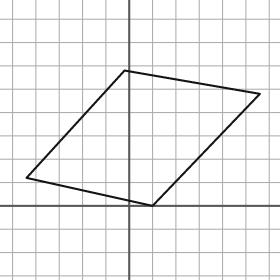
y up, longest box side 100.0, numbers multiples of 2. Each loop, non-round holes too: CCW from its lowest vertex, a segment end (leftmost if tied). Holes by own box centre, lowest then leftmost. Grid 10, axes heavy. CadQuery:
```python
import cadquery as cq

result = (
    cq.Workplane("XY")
    .moveTo(10.0, 0.0)
    .lineTo(56.0, 48.0)
    .lineTo(-2.0, 58.0)
    .lineTo(-44.0, 12.0)
    .close()
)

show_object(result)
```